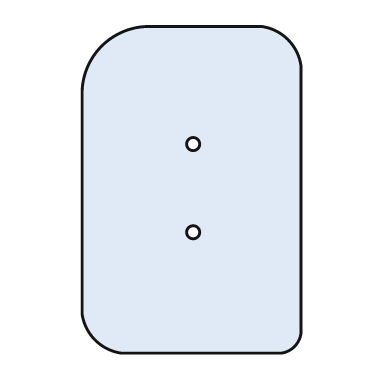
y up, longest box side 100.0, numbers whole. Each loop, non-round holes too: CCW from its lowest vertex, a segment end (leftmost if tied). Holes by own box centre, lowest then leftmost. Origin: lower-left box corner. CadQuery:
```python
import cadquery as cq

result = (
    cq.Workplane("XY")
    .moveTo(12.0, 0.0)
    .lineTo(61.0, 0.0)
    .threePointArc((65.0, 2.0), (67.0, 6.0))
    .lineTo(67.0, 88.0)
    .threePointArc((63.0, 96.0), (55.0, 100.0))
    .lineTo(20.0, 100.0)
    .threePointArc((6.0, 94.0), (0.0, 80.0))
    .lineTo(0.0, 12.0)
    .threePointArc((4.0, 4.0), (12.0, 0.0))
    .close()
    .moveTo(34.0, 37.0)
    .circle(2.0)
    .moveTo(34.0, 64.0)
    .circle(2.0)
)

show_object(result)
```